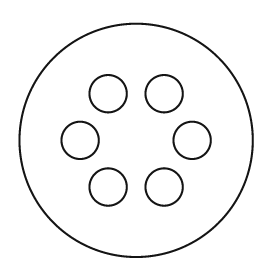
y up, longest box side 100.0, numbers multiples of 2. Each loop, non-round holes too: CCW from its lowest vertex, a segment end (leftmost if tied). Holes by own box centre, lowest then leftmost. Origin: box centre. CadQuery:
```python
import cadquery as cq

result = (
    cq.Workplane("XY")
    .moveTo(0.0, 0.0)
    .circle(50.0)
    .moveTo(-12.0, -20.0)
    .circle(8.0)
    .moveTo(12.0, -20.0)
    .circle(8.0)
    .moveTo(-24.0, 0.0)
    .circle(8.0)
    .moveTo(24.0, 0.0)
    .circle(8.0)
    .moveTo(-12.0, 20.0)
    .circle(8.0)
    .moveTo(12.0, 20.0)
    .circle(8.0)
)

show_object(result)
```